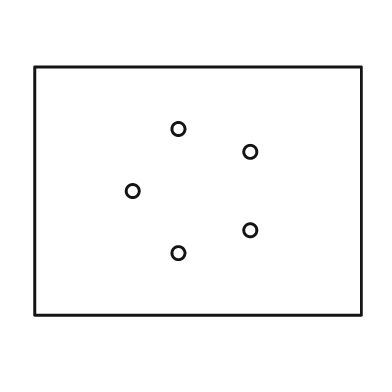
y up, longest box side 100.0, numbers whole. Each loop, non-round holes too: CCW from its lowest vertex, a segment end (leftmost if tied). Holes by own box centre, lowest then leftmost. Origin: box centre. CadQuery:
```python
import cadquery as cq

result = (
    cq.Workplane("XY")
    .moveTo(-50.0, -38.0)
    .lineTo(50.0, -38.0)
    .lineTo(50.0, 38.0)
    .lineTo(-50.0, 38.0)
    .close()
    .moveTo(-6.0, -19.0)
    .circle(2.0)
    .moveTo(16.0, -12.0)
    .circle(2.0)
    .moveTo(-20.0, 0.0)
    .circle(2.0)
    .moveTo(16.0, 12.0)
    .circle(2.0)
    .moveTo(-6.0, 19.0)
    .circle(2.0)
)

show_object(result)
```